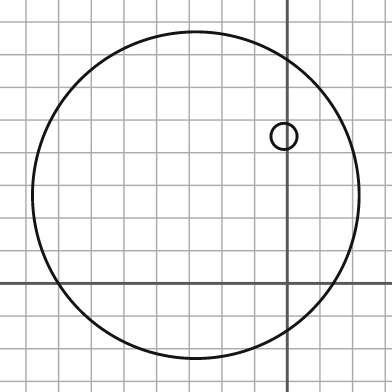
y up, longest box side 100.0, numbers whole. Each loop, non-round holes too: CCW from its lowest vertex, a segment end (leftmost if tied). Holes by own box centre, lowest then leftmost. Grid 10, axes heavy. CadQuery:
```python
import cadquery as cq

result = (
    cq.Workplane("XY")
    .moveTo(-28.0, 27.0)
    .circle(50.0)
    .moveTo(-1.0, 45.0)
    .circle(4.0)
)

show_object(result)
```